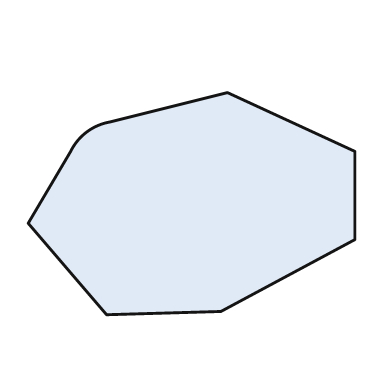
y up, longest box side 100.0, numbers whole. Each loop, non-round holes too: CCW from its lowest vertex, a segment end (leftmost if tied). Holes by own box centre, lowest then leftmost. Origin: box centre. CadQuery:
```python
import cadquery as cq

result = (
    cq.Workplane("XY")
    .moveTo(-26.0, -34.0)
    .lineTo(9.0, -33.0)
    .lineTo(50.0, -11.0)
    .lineTo(50.0, 16.0)
    .lineTo(11.0, 34.0)
    .lineTo(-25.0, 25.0)
    .threePointArc((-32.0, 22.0), (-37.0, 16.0))
    .lineTo(-50.0, -6.0)
    .close()
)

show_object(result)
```